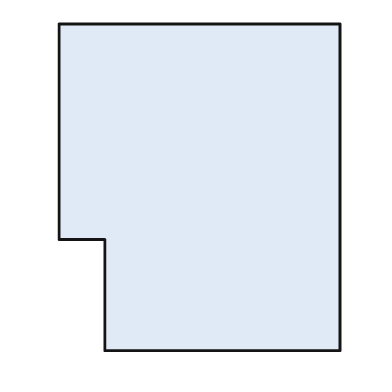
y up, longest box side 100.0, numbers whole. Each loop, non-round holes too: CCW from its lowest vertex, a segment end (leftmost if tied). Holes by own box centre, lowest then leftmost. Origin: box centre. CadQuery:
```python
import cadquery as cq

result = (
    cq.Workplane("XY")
    .moveTo(-29.0, -50.0)
    .lineTo(43.0, -50.0)
    .lineTo(43.0, 50.0)
    .lineTo(-43.0, 50.0)
    .lineTo(-43.0, -16.0)
    .lineTo(-29.0, -16.0)
    .close()
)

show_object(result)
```